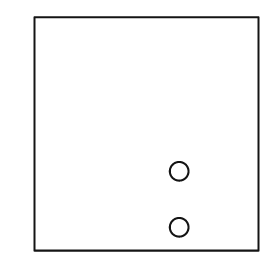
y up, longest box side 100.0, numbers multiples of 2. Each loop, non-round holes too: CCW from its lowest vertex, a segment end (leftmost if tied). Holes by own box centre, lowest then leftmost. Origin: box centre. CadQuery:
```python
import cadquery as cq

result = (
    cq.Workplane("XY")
    .moveTo(-48.0, -50.0)
    .lineTo(48.0, -50.0)
    .lineTo(48.0, 50.0)
    .lineTo(-48.0, 50.0)
    .close()
    .moveTo(14.0, -40.0)
    .circle(4.0)
    .moveTo(14.0, -16.0)
    .circle(4.0)
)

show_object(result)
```